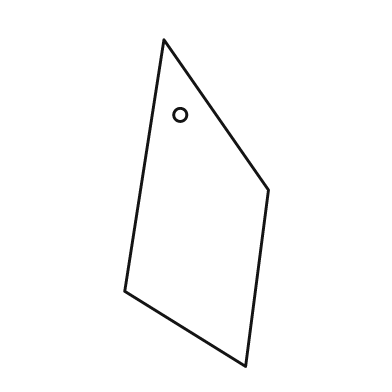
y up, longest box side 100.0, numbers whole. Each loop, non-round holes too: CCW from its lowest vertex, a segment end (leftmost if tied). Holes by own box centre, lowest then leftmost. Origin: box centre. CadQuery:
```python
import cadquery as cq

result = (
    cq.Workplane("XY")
    .moveTo(15.0, -50.0)
    .lineTo(22.0, 4.0)
    .lineTo(-10.0, 50.0)
    .lineTo(-22.0, -27.0)
    .close()
    .moveTo(-5.0, 27.0)
    .circle(2.0)
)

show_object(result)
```